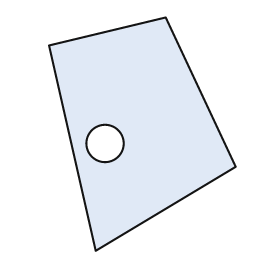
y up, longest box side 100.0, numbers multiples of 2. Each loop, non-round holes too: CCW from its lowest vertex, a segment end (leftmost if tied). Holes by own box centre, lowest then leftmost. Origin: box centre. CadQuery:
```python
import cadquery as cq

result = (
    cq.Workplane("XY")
    .moveTo(-20.0, -50.0)
    .lineTo(40.0, -14.0)
    .lineTo(10.0, 50.0)
    .lineTo(-40.0, 38.0)
    .close()
    .moveTo(-16.0, -4.0)
    .circle(8.0)
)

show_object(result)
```